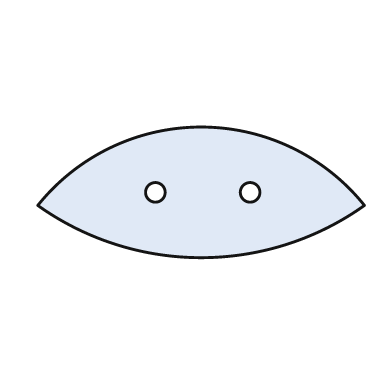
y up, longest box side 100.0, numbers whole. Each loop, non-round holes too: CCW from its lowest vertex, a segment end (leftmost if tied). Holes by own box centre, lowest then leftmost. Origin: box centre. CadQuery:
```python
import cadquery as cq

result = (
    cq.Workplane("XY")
    .moveTo(-50.0, -4.0)
    .threePointArc((0.0, -20.0), (50.0, -4.0))
    .threePointArc((0.0, 20.0), (-50.0, -4.0))
    .close()
    .moveTo(-14.0, 0.0)
    .circle(3.0)
    .moveTo(15.0, 0.0)
    .circle(3.0)
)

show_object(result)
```